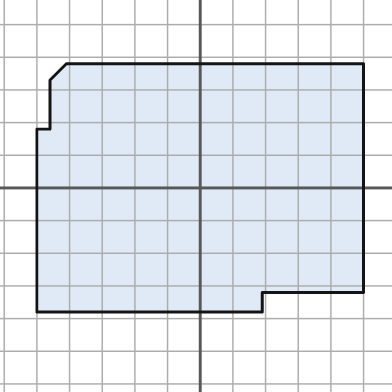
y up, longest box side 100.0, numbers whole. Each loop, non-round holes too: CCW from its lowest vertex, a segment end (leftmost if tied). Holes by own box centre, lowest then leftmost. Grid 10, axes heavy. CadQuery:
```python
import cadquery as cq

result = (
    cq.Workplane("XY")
    .moveTo(-50.0, -38.0)
    .lineTo(19.0, -38.0)
    .lineTo(19.0, -32.0)
    .lineTo(50.0, -32.0)
    .lineTo(50.0, 38.0)
    .lineTo(-41.0, 38.0)
    .lineTo(-46.0, 33.0)
    .lineTo(-46.0, 18.0)
    .lineTo(-50.0, 18.0)
    .close()
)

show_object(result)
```